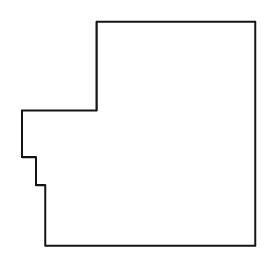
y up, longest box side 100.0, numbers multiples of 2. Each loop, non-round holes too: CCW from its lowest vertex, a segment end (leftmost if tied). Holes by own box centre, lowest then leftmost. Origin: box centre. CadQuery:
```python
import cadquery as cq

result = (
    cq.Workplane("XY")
    .moveTo(-40.0, -48.0)
    .lineTo(50.0, -48.0)
    .lineTo(50.0, 48.0)
    .lineTo(-18.0, 48.0)
    .lineTo(-18.0, 10.0)
    .lineTo(-50.0, 10.0)
    .lineTo(-50.0, -10.0)
    .lineTo(-44.0, -10.0)
    .lineTo(-44.0, -22.0)
    .lineTo(-40.0, -22.0)
    .close()
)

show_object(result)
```